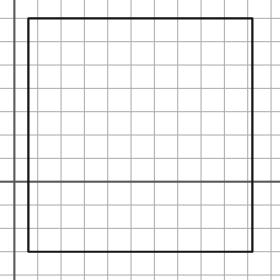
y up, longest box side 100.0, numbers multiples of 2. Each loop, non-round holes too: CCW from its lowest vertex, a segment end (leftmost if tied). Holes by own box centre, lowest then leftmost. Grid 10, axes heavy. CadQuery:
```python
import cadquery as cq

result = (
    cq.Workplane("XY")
    .moveTo(6.0, -30.0)
    .lineTo(102.0, -30.0)
    .lineTo(102.0, 70.0)
    .lineTo(6.0, 70.0)
    .close()
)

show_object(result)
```